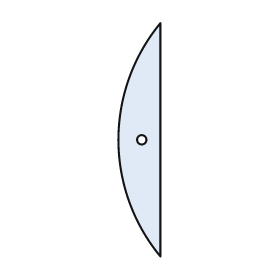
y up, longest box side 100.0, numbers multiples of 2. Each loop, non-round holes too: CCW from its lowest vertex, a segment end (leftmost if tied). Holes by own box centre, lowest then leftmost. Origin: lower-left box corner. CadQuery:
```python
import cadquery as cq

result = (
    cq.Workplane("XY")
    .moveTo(18.0, 0.0)
    .lineTo(18.0, 100.0)
    .threePointArc((0.0, 50.0), (18.0, 0.0))
    .close()
    .moveTo(10.0, 50.0)
    .circle(2.0)
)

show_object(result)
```